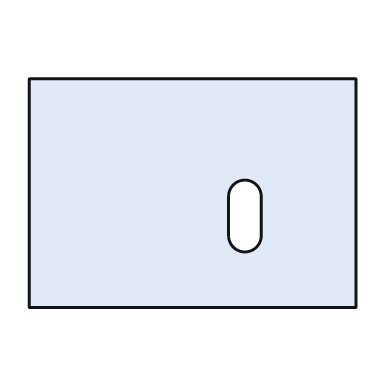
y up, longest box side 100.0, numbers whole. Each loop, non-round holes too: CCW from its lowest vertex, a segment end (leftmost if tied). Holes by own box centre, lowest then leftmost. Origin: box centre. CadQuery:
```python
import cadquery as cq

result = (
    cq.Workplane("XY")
    .moveTo(-50.0, -35.0)
    .lineTo(50.0, -35.0)
    .lineTo(50.0, 35.0)
    .lineTo(-50.0, 35.0)
    .close()
    .moveTo(11.0, -13.0)
    .threePointArc((16.0, -18.0), (21.0, -13.0))
    .lineTo(21.0, -1.0)
    .threePointArc((16.0, 4.0), (11.0, -1.0))
    .close()
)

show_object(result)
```